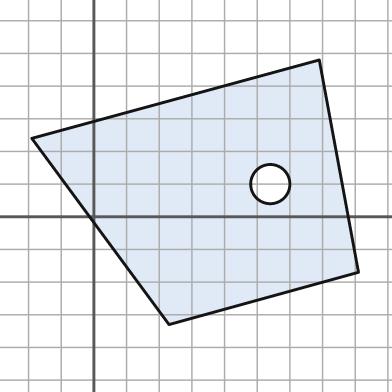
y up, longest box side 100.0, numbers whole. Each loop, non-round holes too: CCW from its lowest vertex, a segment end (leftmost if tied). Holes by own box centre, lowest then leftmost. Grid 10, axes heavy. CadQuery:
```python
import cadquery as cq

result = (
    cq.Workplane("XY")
    .moveTo(23.0, -33.0)
    .lineTo(81.0, -17.0)
    .lineTo(69.0, 48.0)
    .lineTo(-19.0, 24.0)
    .close()
    .moveTo(54.0, 10.0)
    .circle(6.0)
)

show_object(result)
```